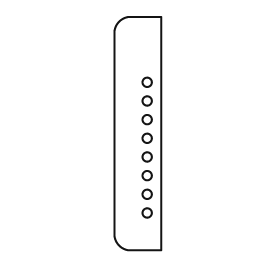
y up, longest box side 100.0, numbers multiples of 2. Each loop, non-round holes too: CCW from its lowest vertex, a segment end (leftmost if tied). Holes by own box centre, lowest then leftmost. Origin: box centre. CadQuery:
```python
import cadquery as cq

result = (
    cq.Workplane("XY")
    .moveTo(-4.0, -50.0)
    .lineTo(10.0, -50.0)
    .lineTo(10.0, 50.0)
    .lineTo(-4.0, 50.0)
    .threePointArc((-8.0, 48.0), (-10.0, 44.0))
    .lineTo(-10.0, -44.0)
    .threePointArc((-8.0, -48.0), (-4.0, -50.0))
    .close()
    .moveTo(4.0, -34.0)
    .circle(2.0)
    .moveTo(4.0, -26.0)
    .circle(2.0)
    .moveTo(4.0, -18.0)
    .circle(2.0)
    .moveTo(4.0, -10.0)
    .circle(2.0)
    .moveTo(4.0, -2.0)
    .circle(2.0)
    .moveTo(4.0, 6.0)
    .circle(2.0)
    .moveTo(4.0, 14.0)
    .circle(2.0)
    .moveTo(4.0, 22.0)
    .circle(2.0)
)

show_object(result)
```